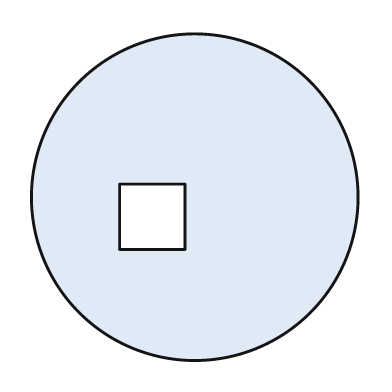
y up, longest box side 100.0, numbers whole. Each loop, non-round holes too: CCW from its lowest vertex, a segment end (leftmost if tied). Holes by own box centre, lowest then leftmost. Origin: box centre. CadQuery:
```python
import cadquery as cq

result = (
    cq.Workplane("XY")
    .moveTo(0.0, 0.0)
    .circle(50.0)
    .moveTo(-23.0, -16.0)
    .lineTo(-3.0, -16.0)
    .lineTo(-3.0, 4.0)
    .lineTo(-23.0, 4.0)
    .close()
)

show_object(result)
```